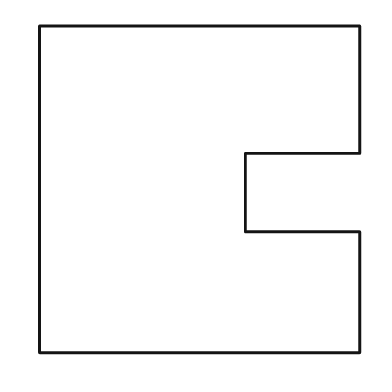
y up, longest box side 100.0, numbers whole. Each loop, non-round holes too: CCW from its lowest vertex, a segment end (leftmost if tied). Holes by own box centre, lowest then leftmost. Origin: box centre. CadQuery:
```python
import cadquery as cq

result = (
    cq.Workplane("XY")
    .moveTo(-49.0, -50.0)
    .lineTo(49.0, -50.0)
    .lineTo(49.0, -13.0)
    .lineTo(14.0, -13.0)
    .lineTo(14.0, 11.0)
    .lineTo(49.0, 11.0)
    .lineTo(49.0, 50.0)
    .lineTo(-49.0, 50.0)
    .close()
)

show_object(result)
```